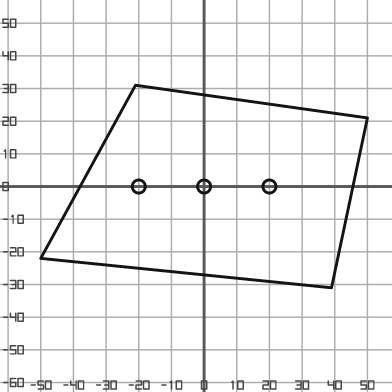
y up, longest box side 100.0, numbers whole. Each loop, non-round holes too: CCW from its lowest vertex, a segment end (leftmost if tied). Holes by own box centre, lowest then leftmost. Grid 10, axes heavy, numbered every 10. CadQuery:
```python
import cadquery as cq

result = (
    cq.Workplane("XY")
    .moveTo(39.0, -31.0)
    .lineTo(50.0, 21.0)
    .lineTo(-21.0, 31.0)
    .lineTo(-50.0, -22.0)
    .close()
    .moveTo(-20.0, 0.0)
    .circle(2.0)
    .moveTo(0.0, 0.0)
    .circle(2.0)
    .moveTo(20.0, 0.0)
    .circle(2.0)
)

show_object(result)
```